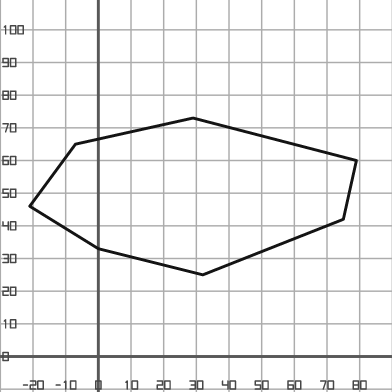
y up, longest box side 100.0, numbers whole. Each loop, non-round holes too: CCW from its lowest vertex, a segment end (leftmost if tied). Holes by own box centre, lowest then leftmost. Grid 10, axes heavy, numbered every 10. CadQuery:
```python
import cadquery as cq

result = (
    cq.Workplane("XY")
    .moveTo(32.0, 25.0)
    .lineTo(75.0, 42.0)
    .lineTo(79.0, 60.0)
    .lineTo(29.0, 73.0)
    .lineTo(-7.0, 65.0)
    .lineTo(-21.0, 46.0)
    .lineTo(0.0, 33.0)
    .close()
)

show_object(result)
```